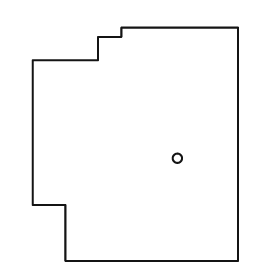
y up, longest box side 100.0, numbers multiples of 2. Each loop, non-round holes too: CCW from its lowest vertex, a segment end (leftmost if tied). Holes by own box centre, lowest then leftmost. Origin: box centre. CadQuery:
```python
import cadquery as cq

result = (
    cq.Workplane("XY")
    .moveTo(-30.0, -50.0)
    .lineTo(44.0, -50.0)
    .lineTo(44.0, 50.0)
    .lineTo(-6.0, 50.0)
    .lineTo(-6.0, 46.0)
    .lineTo(-16.0, 46.0)
    .lineTo(-16.0, 36.0)
    .lineTo(-44.0, 36.0)
    .lineTo(-44.0, -26.0)
    .lineTo(-30.0, -26.0)
    .close()
    .moveTo(18.0, -6.0)
    .circle(2.0)
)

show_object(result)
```